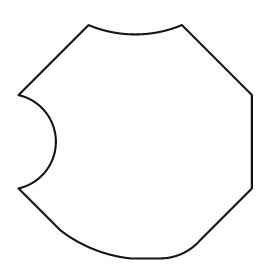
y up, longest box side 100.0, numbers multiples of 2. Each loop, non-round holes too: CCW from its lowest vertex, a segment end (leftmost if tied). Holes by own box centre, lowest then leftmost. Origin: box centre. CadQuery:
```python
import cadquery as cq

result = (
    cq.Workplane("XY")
    .moveTo(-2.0, -50.0)
    .lineTo(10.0, -50.0)
    .threePointArc((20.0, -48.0), (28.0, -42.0))
    .lineTo(50.0, -20.0)
    .lineTo(50.0, 20.0)
    .lineTo(20.0, 50.0)
    .threePointArc((0.0, 46.0), (-20.0, 50.0))
    .lineTo(-50.0, 20.0)
    .threePointArc((-34.0, 0.0), (-50.0, -20.0))
    .lineTo(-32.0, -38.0)
    .threePointArc((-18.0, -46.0), (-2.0, -50.0))
    .close()
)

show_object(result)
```